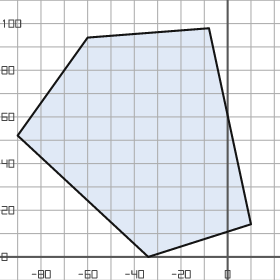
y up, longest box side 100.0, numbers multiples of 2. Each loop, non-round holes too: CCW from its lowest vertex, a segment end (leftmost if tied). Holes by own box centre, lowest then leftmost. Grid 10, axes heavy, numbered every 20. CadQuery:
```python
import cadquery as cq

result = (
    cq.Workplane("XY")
    .moveTo(-34.0, 0.0)
    .lineTo(10.0, 14.0)
    .lineTo(-8.0, 98.0)
    .lineTo(-60.0, 94.0)
    .lineTo(-90.0, 52.0)
    .close()
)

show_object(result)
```